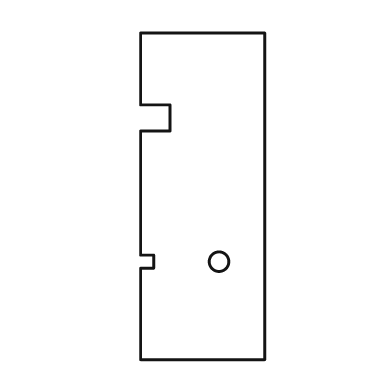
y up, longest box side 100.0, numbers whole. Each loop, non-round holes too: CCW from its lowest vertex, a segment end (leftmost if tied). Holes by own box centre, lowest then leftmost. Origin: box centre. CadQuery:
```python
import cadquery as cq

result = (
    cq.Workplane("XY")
    .moveTo(-19.0, -50.0)
    .lineTo(19.0, -50.0)
    .lineTo(19.0, 50.0)
    .lineTo(-19.0, 50.0)
    .lineTo(-19.0, 28.0)
    .lineTo(-10.0, 28.0)
    .lineTo(-10.0, 20.0)
    .lineTo(-19.0, 20.0)
    .lineTo(-19.0, -18.0)
    .lineTo(-15.0, -18.0)
    .lineTo(-15.0, -22.0)
    .lineTo(-19.0, -22.0)
    .close()
    .moveTo(5.0, -20.0)
    .circle(3.0)
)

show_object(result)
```